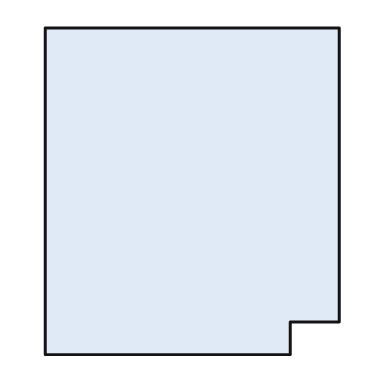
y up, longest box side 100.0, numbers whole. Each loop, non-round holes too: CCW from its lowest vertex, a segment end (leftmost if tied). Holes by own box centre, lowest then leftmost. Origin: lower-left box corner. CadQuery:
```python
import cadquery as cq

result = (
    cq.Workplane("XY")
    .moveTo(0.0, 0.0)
    .lineTo(75.0, 0.0)
    .lineTo(75.0, 10.0)
    .lineTo(90.0, 10.0)
    .lineTo(90.0, 100.0)
    .lineTo(0.0, 100.0)
    .close()
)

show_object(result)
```